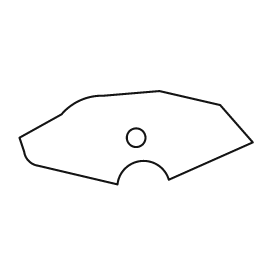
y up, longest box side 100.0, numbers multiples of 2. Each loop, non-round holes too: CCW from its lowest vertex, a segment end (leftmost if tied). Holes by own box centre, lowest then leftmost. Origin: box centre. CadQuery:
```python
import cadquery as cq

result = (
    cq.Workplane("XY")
    .moveTo(-8.0, -20.0)
    .threePointArc((2.0, -10.0), (14.0, -18.0))
    .lineTo(50.0, -2.0)
    .lineTo(36.0, 14.0)
    .lineTo(10.0, 20.0)
    .lineTo(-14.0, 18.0)
    .threePointArc((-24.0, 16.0), (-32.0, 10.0))
    .lineTo(-50.0, 0.0)
    .lineTo(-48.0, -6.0)
    .threePointArc((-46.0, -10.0), (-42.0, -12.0))
    .close()
    .moveTo(0.0, 0.0)
    .circle(4.0)
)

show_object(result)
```